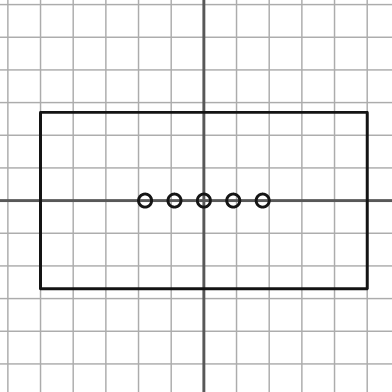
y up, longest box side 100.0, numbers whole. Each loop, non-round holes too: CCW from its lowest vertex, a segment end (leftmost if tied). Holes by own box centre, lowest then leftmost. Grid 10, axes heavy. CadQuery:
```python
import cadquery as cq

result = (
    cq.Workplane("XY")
    .moveTo(-50.0, -27.0)
    .lineTo(50.0, -27.0)
    .lineTo(50.0, 27.0)
    .lineTo(-50.0, 27.0)
    .close()
    .moveTo(-18.0, 0.0)
    .circle(2.0)
    .moveTo(-9.0, 0.0)
    .circle(2.0)
    .moveTo(0.0, 0.0)
    .circle(2.0)
    .moveTo(9.0, 0.0)
    .circle(2.0)
    .moveTo(18.0, 0.0)
    .circle(2.0)
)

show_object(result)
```